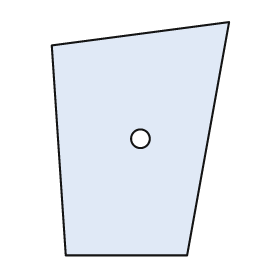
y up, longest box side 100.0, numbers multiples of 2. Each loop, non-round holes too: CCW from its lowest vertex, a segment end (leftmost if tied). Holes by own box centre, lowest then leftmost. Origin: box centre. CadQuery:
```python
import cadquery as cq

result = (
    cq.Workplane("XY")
    .moveTo(-32.0, -50.0)
    .lineTo(20.0, -50.0)
    .lineTo(38.0, 50.0)
    .lineTo(-38.0, 40.0)
    .close()
    .moveTo(0.0, 0.0)
    .circle(4.0)
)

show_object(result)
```